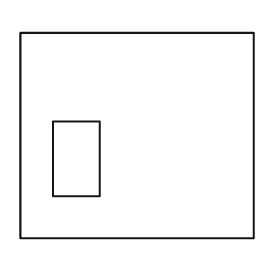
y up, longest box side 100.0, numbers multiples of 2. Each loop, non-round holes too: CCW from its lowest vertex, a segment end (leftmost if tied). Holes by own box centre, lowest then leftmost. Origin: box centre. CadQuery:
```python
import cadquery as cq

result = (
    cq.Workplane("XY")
    .moveTo(-50.0, -44.0)
    .lineTo(50.0, -44.0)
    .lineTo(50.0, 44.0)
    .lineTo(-50.0, 44.0)
    .close()
    .moveTo(-36.0, -26.0)
    .lineTo(-16.0, -26.0)
    .lineTo(-16.0, 6.0)
    .lineTo(-36.0, 6.0)
    .close()
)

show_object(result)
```